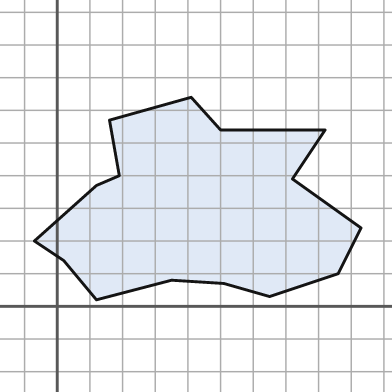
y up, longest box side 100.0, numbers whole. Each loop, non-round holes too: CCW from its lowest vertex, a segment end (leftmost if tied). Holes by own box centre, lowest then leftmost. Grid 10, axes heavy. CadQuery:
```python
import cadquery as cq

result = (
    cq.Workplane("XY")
    .moveTo(12.0, 2.0)
    .lineTo(35.0, 8.0)
    .lineTo(51.0, 7.0)
    .lineTo(65.0, 3.0)
    .lineTo(86.0, 10.0)
    .lineTo(93.0, 24.0)
    .lineTo(72.0, 39.0)
    .lineTo(82.0, 54.0)
    .lineTo(50.0, 54.0)
    .lineTo(41.0, 64.0)
    .lineTo(16.0, 57.0)
    .lineTo(19.0, 40.0)
    .lineTo(12.0, 37.0)
    .lineTo(-7.0, 20.0)
    .lineTo(2.0, 14.0)
    .close()
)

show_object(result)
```